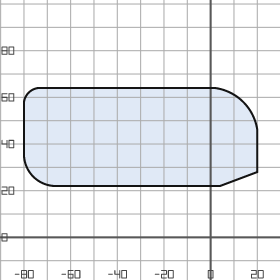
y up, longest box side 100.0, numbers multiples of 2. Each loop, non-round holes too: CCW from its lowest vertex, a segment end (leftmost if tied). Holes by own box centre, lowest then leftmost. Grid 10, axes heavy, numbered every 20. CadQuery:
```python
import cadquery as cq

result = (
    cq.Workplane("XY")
    .moveTo(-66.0, 22.0)
    .lineTo(4.0, 22.0)
    .lineTo(20.0, 28.0)
    .lineTo(20.0, 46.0)
    .threePointArc((14.0, 58.0), (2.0, 64.0))
    .lineTo(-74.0, 64.0)
    .threePointArc((-78.0, 62.0), (-80.0, 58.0))
    .lineTo(-80.0, 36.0)
    .threePointArc((-76.0, 26.0), (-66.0, 22.0))
    .close()
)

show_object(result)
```